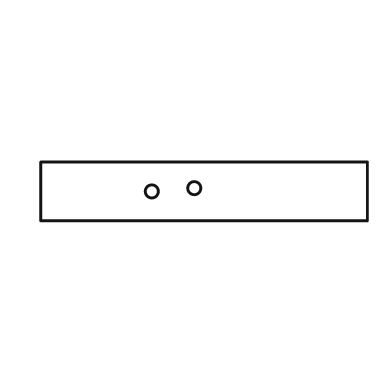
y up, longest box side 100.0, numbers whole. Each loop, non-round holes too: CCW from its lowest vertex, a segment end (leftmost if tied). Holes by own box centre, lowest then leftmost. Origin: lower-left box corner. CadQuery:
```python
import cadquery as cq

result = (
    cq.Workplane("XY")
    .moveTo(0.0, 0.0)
    .lineTo(100.0, 0.0)
    .lineTo(100.0, 18.0)
    .lineTo(0.0, 18.0)
    .close()
    .moveTo(34.0, 9.0)
    .circle(2.0)
    .moveTo(47.0, 10.0)
    .circle(2.0)
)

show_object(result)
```